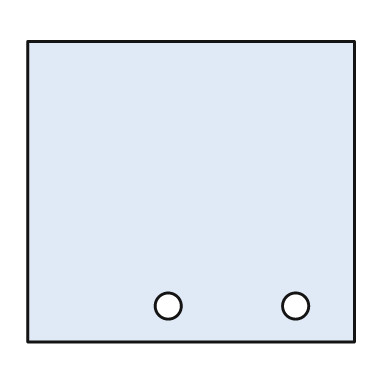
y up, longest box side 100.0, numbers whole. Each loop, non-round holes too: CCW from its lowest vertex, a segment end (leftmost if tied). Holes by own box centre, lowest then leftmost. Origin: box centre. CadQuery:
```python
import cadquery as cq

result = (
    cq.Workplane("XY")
    .moveTo(-50.0, -46.0)
    .lineTo(50.0, -46.0)
    .lineTo(50.0, 46.0)
    .lineTo(-50.0, 46.0)
    .close()
    .moveTo(-7.0, -35.0)
    .circle(4.0)
    .moveTo(32.0, -35.0)
    .circle(4.0)
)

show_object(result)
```